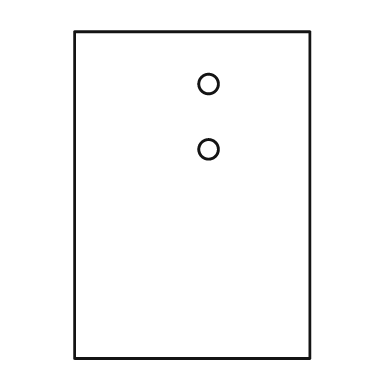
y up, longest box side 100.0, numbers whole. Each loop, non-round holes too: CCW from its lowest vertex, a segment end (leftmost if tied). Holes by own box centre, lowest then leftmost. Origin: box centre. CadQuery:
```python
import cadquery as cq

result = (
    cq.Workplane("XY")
    .moveTo(-36.0, -50.0)
    .lineTo(36.0, -50.0)
    .lineTo(36.0, 50.0)
    .lineTo(-36.0, 50.0)
    .close()
    .moveTo(5.0, 14.0)
    .circle(3.0)
    .moveTo(5.0, 34.0)
    .circle(3.0)
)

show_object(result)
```